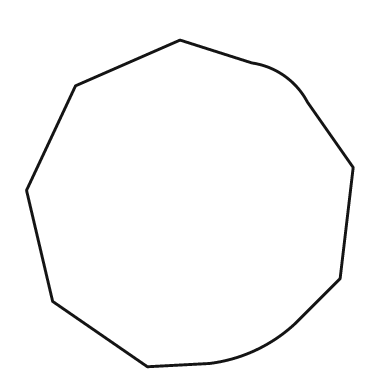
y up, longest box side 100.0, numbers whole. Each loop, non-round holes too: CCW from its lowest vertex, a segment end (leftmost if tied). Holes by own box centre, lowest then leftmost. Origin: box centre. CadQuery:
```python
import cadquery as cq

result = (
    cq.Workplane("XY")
    .moveTo(-13.0, -50.0)
    .lineTo(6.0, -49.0)
    .threePointArc((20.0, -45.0), (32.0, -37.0))
    .lineTo(46.0, -23.0)
    .lineTo(50.0, 11.0)
    .lineTo(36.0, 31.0)
    .threePointArc((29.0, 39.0), (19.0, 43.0))
    .lineTo(-3.0, 50.0)
    .lineTo(-35.0, 36.0)
    .lineTo(-50.0, 4.0)
    .lineTo(-42.0, -30.0)
    .close()
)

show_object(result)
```